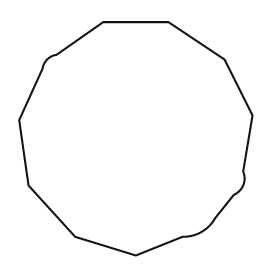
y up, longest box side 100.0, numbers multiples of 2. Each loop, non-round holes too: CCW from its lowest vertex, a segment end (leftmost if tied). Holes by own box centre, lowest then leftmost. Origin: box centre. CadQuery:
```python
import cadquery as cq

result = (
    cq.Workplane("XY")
    .moveTo(0.0, -50.0)
    .lineTo(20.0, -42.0)
    .threePointArc((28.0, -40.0), (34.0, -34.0))
    .lineTo(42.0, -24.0)
    .threePointArc((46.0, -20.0), (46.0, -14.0))
    .lineTo(50.0, 10.0)
    .lineTo(38.0, 34.0)
    .lineTo(14.0, 50.0)
    .lineTo(-14.0, 50.0)
    .lineTo(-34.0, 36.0)
    .threePointArc((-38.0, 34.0), (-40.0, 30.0))
    .lineTo(-50.0, 8.0)
    .lineTo(-46.0, -20.0)
    .lineTo(-26.0, -42.0)
    .close()
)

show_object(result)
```